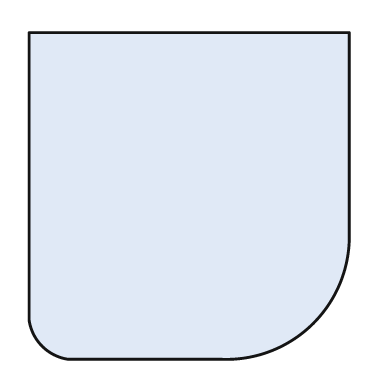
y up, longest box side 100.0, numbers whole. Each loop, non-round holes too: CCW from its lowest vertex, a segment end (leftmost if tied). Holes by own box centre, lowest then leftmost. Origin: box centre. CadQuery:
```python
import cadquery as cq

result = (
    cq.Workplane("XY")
    .moveTo(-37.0, -50.0)
    .lineTo(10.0, -50.0)
    .threePointArc((38.0, -39.0), (49.0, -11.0))
    .lineTo(49.0, 50.0)
    .lineTo(-49.0, 50.0)
    .lineTo(-49.0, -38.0)
    .threePointArc((-45.0, -46.0), (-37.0, -50.0))
    .close()
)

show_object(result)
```